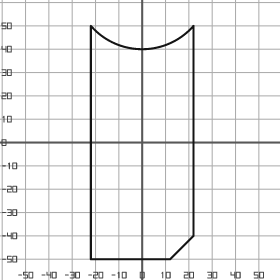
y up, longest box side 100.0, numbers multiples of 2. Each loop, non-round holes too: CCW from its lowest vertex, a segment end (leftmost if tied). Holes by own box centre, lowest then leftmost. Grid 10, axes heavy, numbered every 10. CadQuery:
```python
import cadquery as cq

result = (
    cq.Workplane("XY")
    .moveTo(-22.0, -50.0)
    .lineTo(12.0, -50.0)
    .lineTo(22.0, -40.0)
    .lineTo(22.0, 50.0)
    .threePointArc((0.0, 40.0), (-22.0, 50.0))
    .close()
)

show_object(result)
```